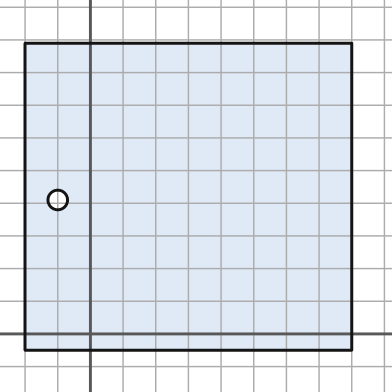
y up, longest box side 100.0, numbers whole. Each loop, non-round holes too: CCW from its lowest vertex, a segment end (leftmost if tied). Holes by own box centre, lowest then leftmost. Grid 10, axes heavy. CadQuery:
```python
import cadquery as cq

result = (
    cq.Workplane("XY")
    .moveTo(-20.0, -5.0)
    .lineTo(80.0, -5.0)
    .lineTo(80.0, 89.0)
    .lineTo(-20.0, 89.0)
    .close()
    .moveTo(-10.0, 41.0)
    .circle(3.0)
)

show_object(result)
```